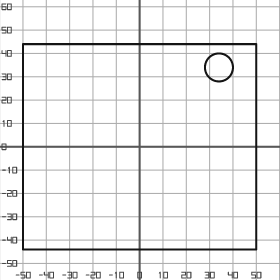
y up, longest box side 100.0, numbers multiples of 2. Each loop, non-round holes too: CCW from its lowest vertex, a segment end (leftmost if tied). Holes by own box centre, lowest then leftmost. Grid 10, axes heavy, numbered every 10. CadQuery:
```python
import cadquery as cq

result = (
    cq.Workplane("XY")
    .moveTo(-50.0, -44.0)
    .lineTo(50.0, -44.0)
    .lineTo(50.0, 44.0)
    .lineTo(-50.0, 44.0)
    .close()
    .moveTo(34.0, 34.0)
    .circle(6.0)
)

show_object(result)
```